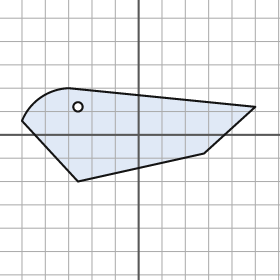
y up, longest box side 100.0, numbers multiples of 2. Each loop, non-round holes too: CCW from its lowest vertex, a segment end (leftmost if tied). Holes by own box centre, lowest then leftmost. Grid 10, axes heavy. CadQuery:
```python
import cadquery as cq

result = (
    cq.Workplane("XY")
    .moveTo(-26.0, -20.0)
    .lineTo(28.0, -8.0)
    .lineTo(50.0, 12.0)
    .lineTo(-30.0, 20.0)
    .threePointArc((-42.0, 16.0), (-50.0, 6.0))
    .close()
    .moveTo(-26.0, 12.0)
    .circle(2.0)
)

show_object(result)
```